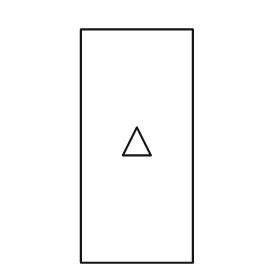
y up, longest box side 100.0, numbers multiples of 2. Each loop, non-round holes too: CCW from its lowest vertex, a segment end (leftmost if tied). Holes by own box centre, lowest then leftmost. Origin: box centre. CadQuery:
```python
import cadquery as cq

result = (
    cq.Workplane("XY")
    .moveTo(-24.0, -50.0)
    .lineTo(24.0, -50.0)
    .lineTo(24.0, 50.0)
    .lineTo(-24.0, 50.0)
    .close()
    .moveTo(-6.0, -4.0)
    .lineTo(6.0, -4.0)
    .lineTo(0.0, 8.0)
    .close()
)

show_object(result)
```